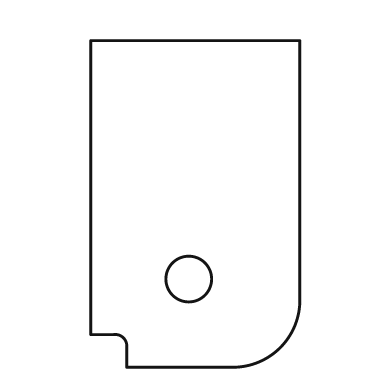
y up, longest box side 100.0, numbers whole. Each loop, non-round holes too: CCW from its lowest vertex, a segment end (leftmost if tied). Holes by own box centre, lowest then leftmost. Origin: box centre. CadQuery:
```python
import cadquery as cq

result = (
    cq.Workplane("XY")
    .moveTo(-21.0, -50.0)
    .lineTo(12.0, -50.0)
    .threePointArc((26.0, -44.0), (32.0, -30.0))
    .lineTo(32.0, 50.0)
    .lineTo(-32.0, 50.0)
    .lineTo(-32.0, -40.0)
    .lineTo(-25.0, -40.0)
    .threePointArc((-22.0, -41.0), (-21.0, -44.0))
    .close()
    .moveTo(-2.0, -23.0)
    .circle(7.0)
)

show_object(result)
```